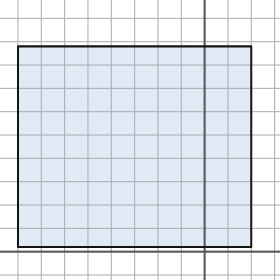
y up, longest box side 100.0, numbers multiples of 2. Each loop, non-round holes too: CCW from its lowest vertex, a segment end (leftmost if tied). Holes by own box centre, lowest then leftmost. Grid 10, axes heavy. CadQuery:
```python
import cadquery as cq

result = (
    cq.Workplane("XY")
    .moveTo(-80.0, 2.0)
    .lineTo(20.0, 2.0)
    .lineTo(20.0, 88.0)
    .lineTo(-80.0, 88.0)
    .close()
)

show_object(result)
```